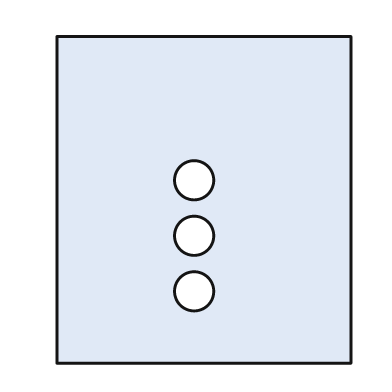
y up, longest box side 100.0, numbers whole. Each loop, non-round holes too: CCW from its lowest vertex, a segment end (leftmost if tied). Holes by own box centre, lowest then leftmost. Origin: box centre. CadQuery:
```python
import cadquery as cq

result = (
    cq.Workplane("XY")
    .moveTo(-45.0, -50.0)
    .lineTo(45.0, -50.0)
    .lineTo(45.0, 50.0)
    .lineTo(-45.0, 50.0)
    .close()
    .moveTo(-3.0, -28.0)
    .circle(6.0)
    .moveTo(-3.0, -11.0)
    .circle(6.0)
    .moveTo(-3.0, 6.0)
    .circle(6.0)
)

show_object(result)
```